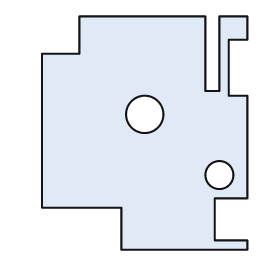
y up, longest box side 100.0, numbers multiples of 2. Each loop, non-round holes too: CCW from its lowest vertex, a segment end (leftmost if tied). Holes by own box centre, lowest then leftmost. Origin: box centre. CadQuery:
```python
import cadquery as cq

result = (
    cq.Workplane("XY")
    .moveTo(-10.0, -50.0)
    .lineTo(44.0, -50.0)
    .lineTo(44.0, -46.0)
    .lineTo(30.0, -46.0)
    .lineTo(30.0, -28.0)
    .lineTo(44.0, -28.0)
    .lineTo(44.0, 16.0)
    .lineTo(36.0, 16.0)
    .lineTo(36.0, 40.0)
    .lineTo(44.0, 40.0)
    .lineTo(44.0, 50.0)
    .lineTo(32.0, 50.0)
    .lineTo(32.0, 18.0)
    .lineTo(26.0, 18.0)
    .lineTo(26.0, 50.0)
    .lineTo(-28.0, 50.0)
    .lineTo(-28.0, 34.0)
    .lineTo(-44.0, 34.0)
    .lineTo(-44.0, -32.0)
    .lineTo(-10.0, -32.0)
    .close()
    .moveTo(32.0, -18.0)
    .circle(6.0)
    .moveTo(0.0, 8.0)
    .circle(8.0)
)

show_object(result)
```